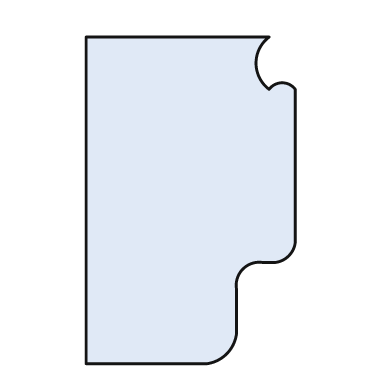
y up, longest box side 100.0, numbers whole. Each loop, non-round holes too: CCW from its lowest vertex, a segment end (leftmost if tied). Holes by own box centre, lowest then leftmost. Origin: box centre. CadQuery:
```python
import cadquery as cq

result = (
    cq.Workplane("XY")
    .moveTo(-32.0, -50.0)
    .lineTo(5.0, -50.0)
    .threePointArc((11.0, -47.0), (14.0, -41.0))
    .lineTo(14.0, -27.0)
    .threePointArc((16.0, -21.0), (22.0, -19.0))
    .lineTo(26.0, -19.0)
    .threePointArc((30.0, -17.0), (32.0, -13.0))
    .lineTo(32.0, 34.0)
    .threePointArc((28.0, 36.0), (24.0, 34.0))
    .threePointArc((20.0, 42.0), (24.0, 50.0))
    .lineTo(-32.0, 50.0)
    .close()
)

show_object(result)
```